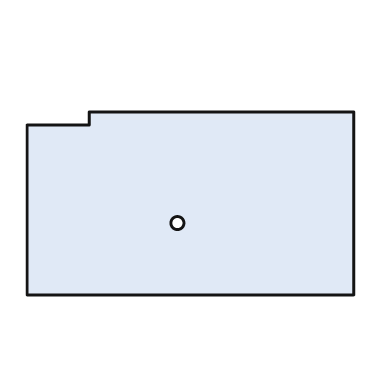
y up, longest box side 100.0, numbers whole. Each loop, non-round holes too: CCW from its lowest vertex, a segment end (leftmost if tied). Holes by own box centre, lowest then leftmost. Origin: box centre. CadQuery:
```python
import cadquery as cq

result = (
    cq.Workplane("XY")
    .moveTo(-50.0, -28.0)
    .lineTo(50.0, -28.0)
    .lineTo(50.0, 28.0)
    .lineTo(-31.0, 28.0)
    .lineTo(-31.0, 24.0)
    .lineTo(-50.0, 24.0)
    .close()
    .moveTo(-4.0, -6.0)
    .circle(2.0)
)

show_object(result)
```